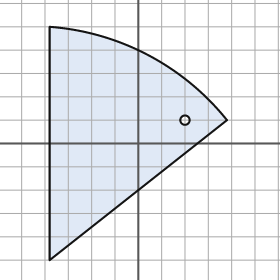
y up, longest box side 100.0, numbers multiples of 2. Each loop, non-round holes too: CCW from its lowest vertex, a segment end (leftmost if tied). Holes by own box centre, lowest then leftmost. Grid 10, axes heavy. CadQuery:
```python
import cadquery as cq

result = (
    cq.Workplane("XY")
    .moveTo(-38.0, -50.0)
    .lineTo(38.0, 10.0)
    .threePointArc((4.0, 38.0), (-38.0, 50.0))
    .close()
    .moveTo(20.0, 10.0)
    .circle(2.0)
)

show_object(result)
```